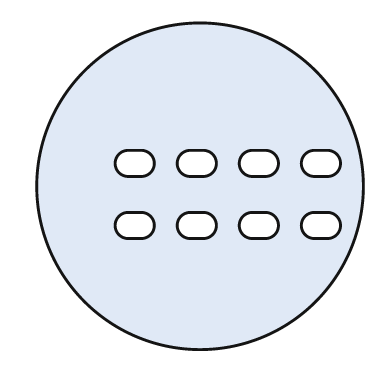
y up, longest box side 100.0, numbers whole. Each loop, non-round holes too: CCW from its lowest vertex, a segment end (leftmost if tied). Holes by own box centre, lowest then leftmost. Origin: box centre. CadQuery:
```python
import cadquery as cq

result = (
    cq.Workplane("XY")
    .moveTo(0.0, 0.0)
    .circle(50.0)
    .moveTo(-22.0, -16.0)
    .lineTo(-18.0, -16.0)
    .threePointArc((-14.0, -12.0), (-18.0, -8.0))
    .lineTo(-22.0, -8.0)
    .threePointArc((-26.0, -12.0), (-22.0, -16.0))
    .close()
    .moveTo(-3.0, -16.0)
    .lineTo(1.0, -16.0)
    .threePointArc((5.0, -12.0), (1.0, -8.0))
    .lineTo(-3.0, -8.0)
    .threePointArc((-7.0, -12.0), (-3.0, -16.0))
    .close()
    .moveTo(16.0, -16.0)
    .lineTo(20.0, -16.0)
    .threePointArc((24.0, -12.0), (20.0, -8.0))
    .lineTo(16.0, -8.0)
    .threePointArc((12.0, -12.0), (16.0, -16.0))
    .close()
    .moveTo(35.0, -16.0)
    .lineTo(39.0, -16.0)
    .threePointArc((43.0, -12.0), (39.0, -8.0))
    .lineTo(35.0, -8.0)
    .threePointArc((31.0, -12.0), (35.0, -16.0))
    .close()
    .moveTo(-22.0, 3.0)
    .lineTo(-18.0, 3.0)
    .threePointArc((-14.0, 7.0), (-18.0, 11.0))
    .lineTo(-22.0, 11.0)
    .threePointArc((-26.0, 7.0), (-22.0, 3.0))
    .close()
    .moveTo(-3.0, 3.0)
    .lineTo(1.0, 3.0)
    .threePointArc((5.0, 7.0), (1.0, 11.0))
    .lineTo(-3.0, 11.0)
    .threePointArc((-7.0, 7.0), (-3.0, 3.0))
    .close()
    .moveTo(16.0, 3.0)
    .lineTo(20.0, 3.0)
    .threePointArc((24.0, 7.0), (20.0, 11.0))
    .lineTo(16.0, 11.0)
    .threePointArc((12.0, 7.0), (16.0, 3.0))
    .close()
    .moveTo(35.0, 3.0)
    .lineTo(39.0, 3.0)
    .threePointArc((43.0, 7.0), (39.0, 11.0))
    .lineTo(35.0, 11.0)
    .threePointArc((31.0, 7.0), (35.0, 3.0))
    .close()
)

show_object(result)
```